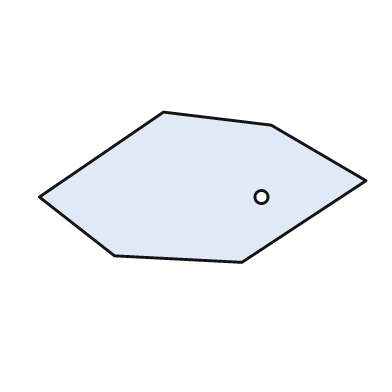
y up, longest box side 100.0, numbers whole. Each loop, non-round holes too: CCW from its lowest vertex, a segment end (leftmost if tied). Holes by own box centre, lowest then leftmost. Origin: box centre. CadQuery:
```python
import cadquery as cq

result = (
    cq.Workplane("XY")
    .moveTo(12.0, -23.0)
    .lineTo(50.0, 2.0)
    .lineTo(21.0, 19.0)
    .lineTo(-12.0, 23.0)
    .lineTo(-50.0, -3.0)
    .lineTo(-27.0, -21.0)
    .close()
    .moveTo(18.0, -3.0)
    .circle(2.0)
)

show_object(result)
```